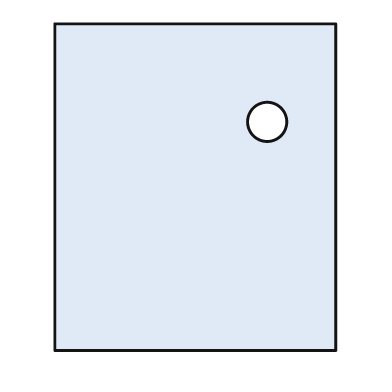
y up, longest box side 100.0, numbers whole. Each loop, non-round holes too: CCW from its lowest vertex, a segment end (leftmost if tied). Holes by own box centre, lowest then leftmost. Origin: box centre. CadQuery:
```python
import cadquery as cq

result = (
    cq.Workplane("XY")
    .moveTo(-43.0, -50.0)
    .lineTo(43.0, -50.0)
    .lineTo(43.0, 50.0)
    .lineTo(-43.0, 50.0)
    .close()
    .moveTo(22.0, 20.0)
    .circle(6.0)
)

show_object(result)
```